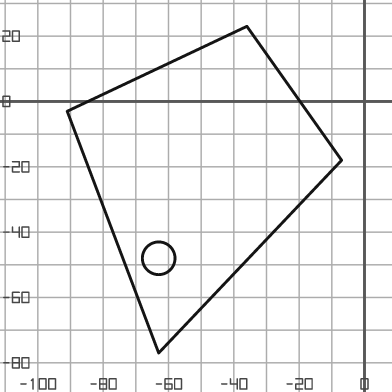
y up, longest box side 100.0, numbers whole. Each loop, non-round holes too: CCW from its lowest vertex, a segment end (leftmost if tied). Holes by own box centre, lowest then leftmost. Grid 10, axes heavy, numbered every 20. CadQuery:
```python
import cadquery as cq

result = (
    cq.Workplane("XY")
    .moveTo(-63.0, -77.0)
    .lineTo(-7.0, -18.0)
    .lineTo(-36.0, 23.0)
    .lineTo(-91.0, -3.0)
    .close()
    .moveTo(-63.0, -48.0)
    .circle(5.0)
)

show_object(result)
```